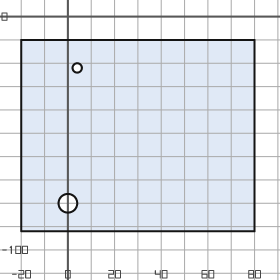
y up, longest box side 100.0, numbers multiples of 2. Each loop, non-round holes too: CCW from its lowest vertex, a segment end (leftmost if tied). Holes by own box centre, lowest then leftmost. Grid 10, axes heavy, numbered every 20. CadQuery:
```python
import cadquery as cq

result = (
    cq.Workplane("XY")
    .moveTo(-20.0, -92.0)
    .lineTo(80.0, -92.0)
    .lineTo(80.0, -10.0)
    .lineTo(-20.0, -10.0)
    .close()
    .moveTo(0.0, -80.0)
    .circle(4.0)
    .moveTo(4.0, -22.0)
    .circle(2.0)
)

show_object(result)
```